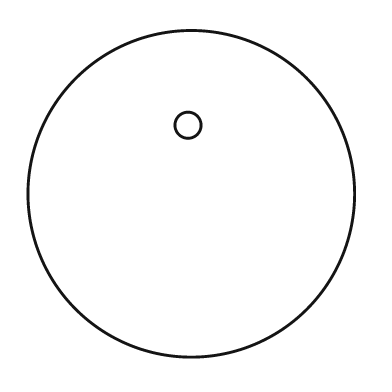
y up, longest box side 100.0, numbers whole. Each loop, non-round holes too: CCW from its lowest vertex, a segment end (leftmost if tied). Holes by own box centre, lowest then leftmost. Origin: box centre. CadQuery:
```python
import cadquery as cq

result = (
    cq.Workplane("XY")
    .moveTo(0.0, 0.0)
    .circle(50.0)
    .moveTo(-1.0, 21.0)
    .circle(4.0)
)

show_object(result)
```